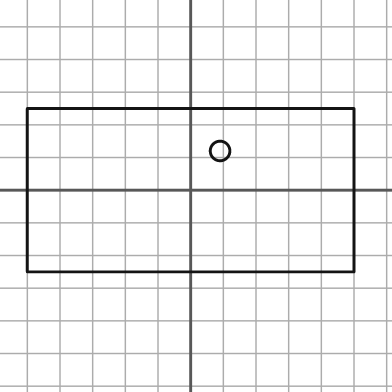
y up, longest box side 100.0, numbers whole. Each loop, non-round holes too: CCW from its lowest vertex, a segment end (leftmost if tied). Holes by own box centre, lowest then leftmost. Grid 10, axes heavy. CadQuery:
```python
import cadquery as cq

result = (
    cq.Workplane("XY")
    .moveTo(-50.0, -25.0)
    .lineTo(50.0, -25.0)
    .lineTo(50.0, 25.0)
    .lineTo(-50.0, 25.0)
    .close()
    .moveTo(9.0, 12.0)
    .circle(3.0)
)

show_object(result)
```